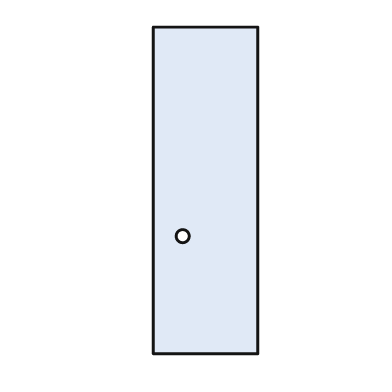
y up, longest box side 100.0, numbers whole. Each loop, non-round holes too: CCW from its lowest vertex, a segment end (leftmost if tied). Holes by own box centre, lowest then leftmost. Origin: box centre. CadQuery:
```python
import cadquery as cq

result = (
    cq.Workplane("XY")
    .moveTo(-16.0, -50.0)
    .lineTo(16.0, -50.0)
    .lineTo(16.0, 50.0)
    .lineTo(-16.0, 50.0)
    .close()
    .moveTo(-7.0, -14.0)
    .circle(2.0)
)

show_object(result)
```